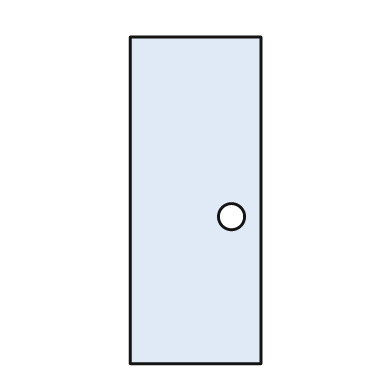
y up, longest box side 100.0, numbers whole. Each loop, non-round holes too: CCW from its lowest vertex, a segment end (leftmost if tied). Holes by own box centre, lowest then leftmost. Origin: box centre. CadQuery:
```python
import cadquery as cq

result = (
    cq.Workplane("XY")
    .moveTo(-20.0, -50.0)
    .lineTo(20.0, -50.0)
    .lineTo(20.0, 50.0)
    .lineTo(-20.0, 50.0)
    .close()
    .moveTo(11.0, -5.0)
    .circle(4.0)
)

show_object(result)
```